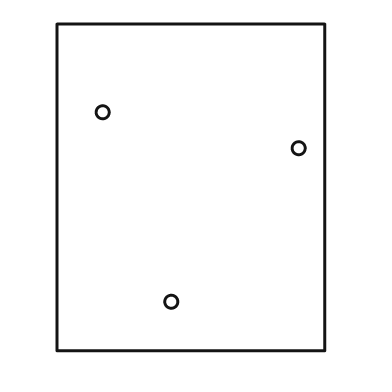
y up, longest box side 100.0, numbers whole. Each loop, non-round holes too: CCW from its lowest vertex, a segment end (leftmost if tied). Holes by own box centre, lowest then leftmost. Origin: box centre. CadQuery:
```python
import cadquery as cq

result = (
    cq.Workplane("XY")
    .moveTo(-41.0, -50.0)
    .lineTo(41.0, -50.0)
    .lineTo(41.0, 50.0)
    .lineTo(-41.0, 50.0)
    .close()
    .moveTo(-6.0, -35.0)
    .circle(2.0)
    .moveTo(33.0, 12.0)
    .circle(2.0)
    .moveTo(-27.0, 23.0)
    .circle(2.0)
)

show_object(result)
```